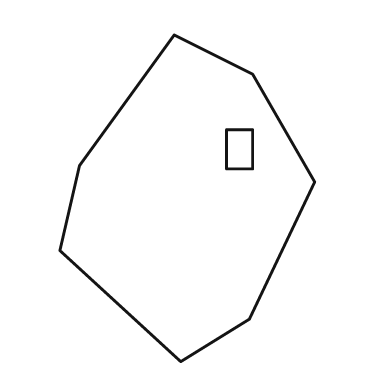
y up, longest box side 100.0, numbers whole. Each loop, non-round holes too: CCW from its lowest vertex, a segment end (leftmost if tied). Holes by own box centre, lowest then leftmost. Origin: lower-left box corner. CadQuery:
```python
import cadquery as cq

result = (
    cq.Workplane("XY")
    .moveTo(37.0, 0.0)
    .lineTo(58.0, 13.0)
    .lineTo(78.0, 55.0)
    .lineTo(59.0, 88.0)
    .lineTo(35.0, 100.0)
    .lineTo(6.0, 60.0)
    .lineTo(0.0, 34.0)
    .close()
    .moveTo(51.0, 59.0)
    .lineTo(59.0, 59.0)
    .lineTo(59.0, 71.0)
    .lineTo(51.0, 71.0)
    .close()
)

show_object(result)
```